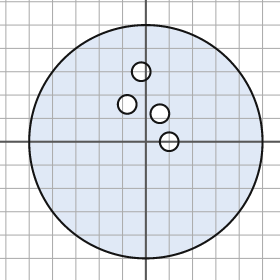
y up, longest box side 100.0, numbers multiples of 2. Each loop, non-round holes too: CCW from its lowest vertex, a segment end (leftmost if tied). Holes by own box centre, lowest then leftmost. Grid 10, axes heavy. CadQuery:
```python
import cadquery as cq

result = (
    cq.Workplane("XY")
    .moveTo(0.0, 0.0)
    .circle(50.0)
    .moveTo(10.0, 0.0)
    .circle(4.0)
    .moveTo(6.0, 12.0)
    .circle(4.0)
    .moveTo(-8.0, 16.0)
    .circle(4.0)
    .moveTo(-2.0, 30.0)
    .circle(4.0)
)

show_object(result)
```